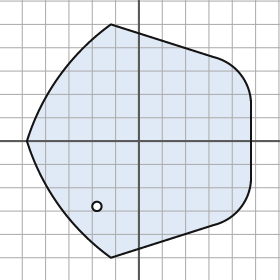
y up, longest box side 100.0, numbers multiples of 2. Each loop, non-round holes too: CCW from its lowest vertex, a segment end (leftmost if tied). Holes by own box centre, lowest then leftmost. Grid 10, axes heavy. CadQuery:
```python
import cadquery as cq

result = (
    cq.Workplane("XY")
    .moveTo(-12.0, -50.0)
    .lineTo(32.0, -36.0)
    .threePointArc((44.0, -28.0), (48.0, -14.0))
    .lineTo(48.0, 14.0)
    .threePointArc((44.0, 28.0), (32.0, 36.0))
    .lineTo(-12.0, 50.0)
    .threePointArc((-34.0, 28.0), (-48.0, 0.0))
    .threePointArc((-34.0, -28.0), (-12.0, -50.0))
    .close()
    .moveTo(-18.0, -28.0)
    .circle(2.0)
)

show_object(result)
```